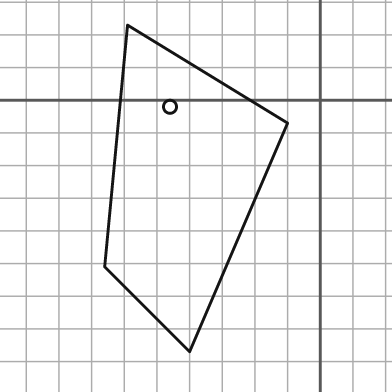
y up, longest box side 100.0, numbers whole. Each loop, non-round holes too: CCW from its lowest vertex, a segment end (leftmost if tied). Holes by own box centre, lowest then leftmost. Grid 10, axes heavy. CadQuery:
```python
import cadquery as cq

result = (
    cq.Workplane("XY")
    .moveTo(-40.0, -77.0)
    .lineTo(-10.0, -7.0)
    .lineTo(-59.0, 23.0)
    .lineTo(-66.0, -51.0)
    .close()
    .moveTo(-46.0, -2.0)
    .circle(2.0)
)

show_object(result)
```